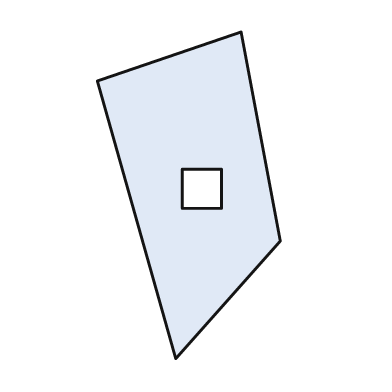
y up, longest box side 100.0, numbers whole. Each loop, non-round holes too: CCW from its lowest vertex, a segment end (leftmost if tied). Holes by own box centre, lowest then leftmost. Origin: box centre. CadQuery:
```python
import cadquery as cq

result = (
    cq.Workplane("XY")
    .moveTo(-4.0, -50.0)
    .lineTo(28.0, -14.0)
    .lineTo(16.0, 50.0)
    .lineTo(-28.0, 35.0)
    .close()
    .moveTo(-2.0, -4.0)
    .lineTo(10.0, -4.0)
    .lineTo(10.0, 8.0)
    .lineTo(-2.0, 8.0)
    .close()
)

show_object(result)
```